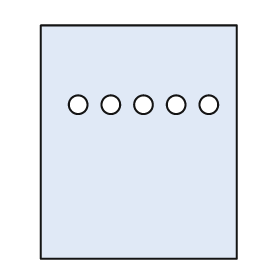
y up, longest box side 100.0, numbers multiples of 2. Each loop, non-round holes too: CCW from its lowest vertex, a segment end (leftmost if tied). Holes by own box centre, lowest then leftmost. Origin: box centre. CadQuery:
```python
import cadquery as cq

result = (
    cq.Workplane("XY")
    .moveTo(-42.0, -50.0)
    .lineTo(42.0, -50.0)
    .lineTo(42.0, 50.0)
    .lineTo(-42.0, 50.0)
    .close()
    .moveTo(-26.0, 16.0)
    .circle(4.0)
    .moveTo(-12.0, 16.0)
    .circle(4.0)
    .moveTo(2.0, 16.0)
    .circle(4.0)
    .moveTo(16.0, 16.0)
    .circle(4.0)
    .moveTo(30.0, 16.0)
    .circle(4.0)
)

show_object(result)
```